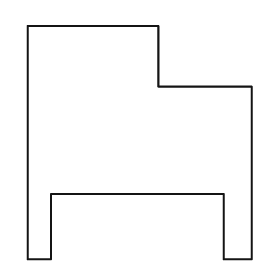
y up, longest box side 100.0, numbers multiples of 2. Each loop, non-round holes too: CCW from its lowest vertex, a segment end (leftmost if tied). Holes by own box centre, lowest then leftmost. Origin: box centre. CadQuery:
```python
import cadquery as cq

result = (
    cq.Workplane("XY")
    .moveTo(-48.0, -50.0)
    .lineTo(-38.0, -50.0)
    .lineTo(-38.0, -22.0)
    .lineTo(36.0, -22.0)
    .lineTo(36.0, -50.0)
    .lineTo(48.0, -50.0)
    .lineTo(48.0, 24.0)
    .lineTo(8.0, 24.0)
    .lineTo(8.0, 50.0)
    .lineTo(-48.0, 50.0)
    .close()
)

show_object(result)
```